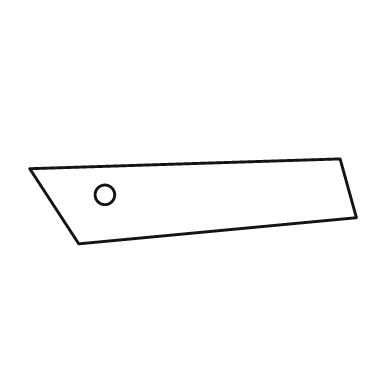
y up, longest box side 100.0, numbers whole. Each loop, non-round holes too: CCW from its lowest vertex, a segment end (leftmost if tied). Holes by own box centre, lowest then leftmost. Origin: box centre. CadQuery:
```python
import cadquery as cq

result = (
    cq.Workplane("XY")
    .moveTo(-35.0, -13.0)
    .lineTo(50.0, -5.0)
    .lineTo(45.0, 13.0)
    .lineTo(-50.0, 10.0)
    .close()
    .moveTo(-27.0, 2.0)
    .circle(3.0)
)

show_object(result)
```